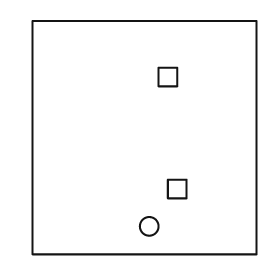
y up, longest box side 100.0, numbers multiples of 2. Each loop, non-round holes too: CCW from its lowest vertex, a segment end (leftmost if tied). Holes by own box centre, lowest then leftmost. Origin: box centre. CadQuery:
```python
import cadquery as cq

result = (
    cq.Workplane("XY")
    .moveTo(-48.0, -50.0)
    .lineTo(48.0, -50.0)
    .lineTo(48.0, 50.0)
    .lineTo(-48.0, 50.0)
    .close()
    .moveTo(2.0, -38.0)
    .circle(4.0)
    .moveTo(10.0, -26.0)
    .lineTo(18.0, -26.0)
    .lineTo(18.0, -18.0)
    .lineTo(10.0, -18.0)
    .close()
    .moveTo(6.0, 22.0)
    .lineTo(14.0, 22.0)
    .lineTo(14.0, 30.0)
    .lineTo(6.0, 30.0)
    .close()
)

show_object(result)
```